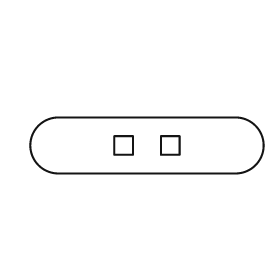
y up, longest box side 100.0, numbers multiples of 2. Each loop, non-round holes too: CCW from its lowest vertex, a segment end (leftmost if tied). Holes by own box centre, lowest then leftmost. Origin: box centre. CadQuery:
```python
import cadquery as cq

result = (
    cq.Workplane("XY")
    .moveTo(-38.0, -12.0)
    .lineTo(38.0, -12.0)
    .threePointArc((50.0, 0.0), (38.0, 12.0))
    .lineTo(-38.0, 12.0)
    .threePointArc((-50.0, 0.0), (-38.0, -12.0))
    .close()
    .moveTo(-14.0, -4.0)
    .lineTo(-6.0, -4.0)
    .lineTo(-6.0, 4.0)
    .lineTo(-14.0, 4.0)
    .close()
    .moveTo(6.0, -4.0)
    .lineTo(14.0, -4.0)
    .lineTo(14.0, 4.0)
    .lineTo(6.0, 4.0)
    .close()
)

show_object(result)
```